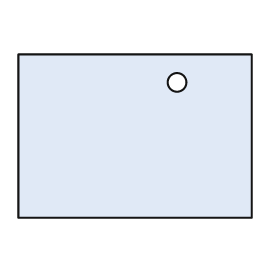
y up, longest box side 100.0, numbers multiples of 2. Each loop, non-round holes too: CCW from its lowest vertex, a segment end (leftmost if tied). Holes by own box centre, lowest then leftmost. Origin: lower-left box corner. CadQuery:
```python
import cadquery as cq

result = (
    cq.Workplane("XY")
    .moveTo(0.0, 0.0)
    .lineTo(100.0, 0.0)
    .lineTo(100.0, 70.0)
    .lineTo(0.0, 70.0)
    .close()
    .moveTo(68.0, 58.0)
    .circle(4.0)
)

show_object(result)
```